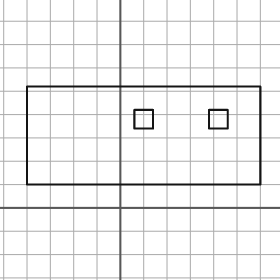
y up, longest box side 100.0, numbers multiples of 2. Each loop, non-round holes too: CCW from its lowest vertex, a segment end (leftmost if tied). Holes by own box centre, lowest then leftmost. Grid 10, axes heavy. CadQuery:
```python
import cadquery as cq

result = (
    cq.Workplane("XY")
    .moveTo(-40.0, 10.0)
    .lineTo(60.0, 10.0)
    .lineTo(60.0, 52.0)
    .lineTo(-40.0, 52.0)
    .close()
    .moveTo(6.0, 34.0)
    .lineTo(14.0, 34.0)
    .lineTo(14.0, 42.0)
    .lineTo(6.0, 42.0)
    .close()
    .moveTo(38.0, 34.0)
    .lineTo(46.0, 34.0)
    .lineTo(46.0, 42.0)
    .lineTo(38.0, 42.0)
    .close()
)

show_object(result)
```